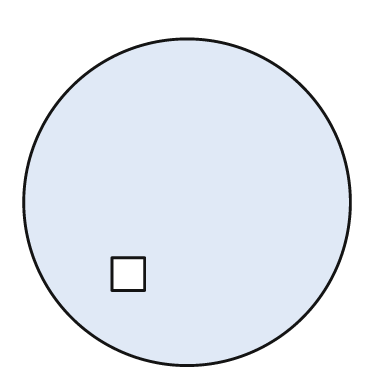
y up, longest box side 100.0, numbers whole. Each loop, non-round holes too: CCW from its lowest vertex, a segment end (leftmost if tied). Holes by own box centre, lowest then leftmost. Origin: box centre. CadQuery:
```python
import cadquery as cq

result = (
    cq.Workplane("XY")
    .moveTo(0.0, 0.0)
    .circle(50.0)
    .moveTo(-23.0, -27.0)
    .lineTo(-13.0, -27.0)
    .lineTo(-13.0, -17.0)
    .lineTo(-23.0, -17.0)
    .close()
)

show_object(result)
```